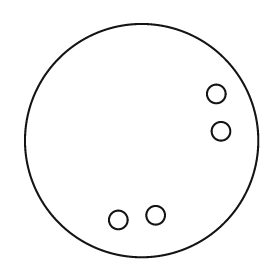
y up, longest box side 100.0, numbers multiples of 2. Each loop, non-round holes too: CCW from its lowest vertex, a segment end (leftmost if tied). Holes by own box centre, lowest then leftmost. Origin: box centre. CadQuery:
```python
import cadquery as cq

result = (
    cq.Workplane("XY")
    .moveTo(0.0, 0.0)
    .circle(50.0)
    .moveTo(-10.0, -34.0)
    .circle(4.0)
    .moveTo(6.0, -32.0)
    .circle(4.0)
    .moveTo(34.0, 4.0)
    .circle(4.0)
    .moveTo(32.0, 20.0)
    .circle(4.0)
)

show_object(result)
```